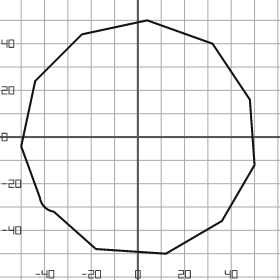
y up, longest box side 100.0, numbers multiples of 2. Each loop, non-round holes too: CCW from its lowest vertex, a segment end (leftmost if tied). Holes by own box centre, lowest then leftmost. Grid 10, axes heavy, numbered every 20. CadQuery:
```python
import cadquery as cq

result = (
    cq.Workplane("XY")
    .moveTo(12.0, -50.0)
    .lineTo(36.0, -36.0)
    .lineTo(50.0, -12.0)
    .lineTo(48.0, 16.0)
    .lineTo(32.0, 40.0)
    .lineTo(4.0, 50.0)
    .lineTo(-24.0, 44.0)
    .lineTo(-44.0, 24.0)
    .lineTo(-50.0, -4.0)
    .lineTo(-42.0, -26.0)
    .threePointArc((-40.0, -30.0), (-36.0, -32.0))
    .lineTo(-18.0, -48.0)
    .close()
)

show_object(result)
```